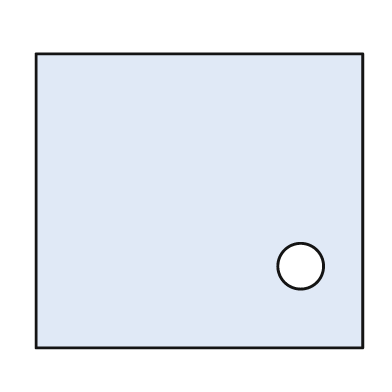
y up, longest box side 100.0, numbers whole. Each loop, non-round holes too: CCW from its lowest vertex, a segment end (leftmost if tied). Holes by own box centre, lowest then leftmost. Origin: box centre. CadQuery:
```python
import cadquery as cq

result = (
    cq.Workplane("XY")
    .moveTo(-50.0, -45.0)
    .lineTo(50.0, -45.0)
    .lineTo(50.0, 45.0)
    .lineTo(-50.0, 45.0)
    .close()
    .moveTo(31.0, -20.0)
    .circle(7.0)
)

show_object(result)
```